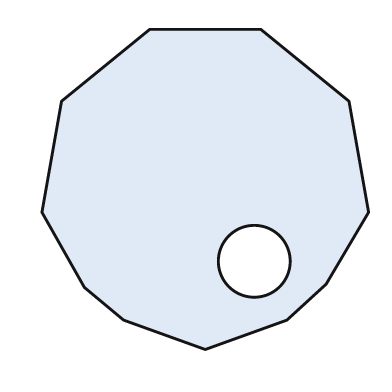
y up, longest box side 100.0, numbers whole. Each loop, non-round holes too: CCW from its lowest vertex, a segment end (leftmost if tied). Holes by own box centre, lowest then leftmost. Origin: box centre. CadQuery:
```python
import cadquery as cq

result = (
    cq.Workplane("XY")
    .moveTo(0.0, -49.0)
    .lineTo(25.0, -40.0)
    .lineTo(37.0, -29.0)
    .lineTo(50.0, -7.0)
    .lineTo(44.0, 27.0)
    .lineTo(17.0, 49.0)
    .lineTo(-17.0, 49.0)
    .lineTo(-44.0, 27.0)
    .lineTo(-50.0, -7.0)
    .lineTo(-37.0, -30.0)
    .lineTo(-25.0, -40.0)
    .close()
    .moveTo(15.0, -22.0)
    .circle(11.0)
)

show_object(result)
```